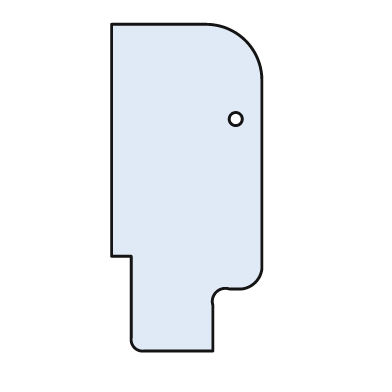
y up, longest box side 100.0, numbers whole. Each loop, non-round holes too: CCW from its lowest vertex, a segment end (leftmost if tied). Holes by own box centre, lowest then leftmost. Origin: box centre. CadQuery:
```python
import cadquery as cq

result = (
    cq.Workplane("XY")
    .moveTo(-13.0, -50.0)
    .lineTo(8.0, -50.0)
    .lineTo(8.0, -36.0)
    .threePointArc((9.0, -32.0), (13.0, -31.0))
    .lineTo(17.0, -31.0)
    .threePointArc((21.0, -29.0), (23.0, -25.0))
    .lineTo(23.0, 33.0)
    .threePointArc((18.0, 45.0), (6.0, 50.0))
    .lineTo(-23.0, 50.0)
    .lineTo(-23.0, -21.0)
    .lineTo(-17.0, -21.0)
    .lineTo(-17.0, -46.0)
    .threePointArc((-16.0, -49.0), (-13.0, -50.0))
    .close()
    .moveTo(15.0, 21.0)
    .circle(2.0)
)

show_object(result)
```